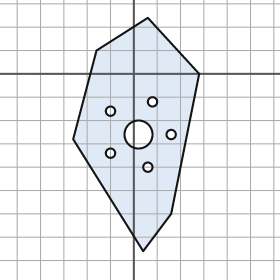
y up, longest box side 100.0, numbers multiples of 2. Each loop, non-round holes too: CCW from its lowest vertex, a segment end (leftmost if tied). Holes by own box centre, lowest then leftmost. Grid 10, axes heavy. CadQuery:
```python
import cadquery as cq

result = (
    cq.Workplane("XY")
    .moveTo(4.0, -76.0)
    .lineTo(16.0, -60.0)
    .lineTo(28.0, 0.0)
    .lineTo(6.0, 24.0)
    .lineTo(-16.0, 10.0)
    .lineTo(-26.0, -28.0)
    .close()
    .moveTo(6.0, -40.0)
    .circle(2.0)
    .moveTo(-10.0, -34.0)
    .circle(2.0)
    .moveTo(2.0, -26.0)
    .circle(6.0)
    .moveTo(16.0, -26.0)
    .circle(2.0)
    .moveTo(-10.0, -16.0)
    .circle(2.0)
    .moveTo(8.0, -12.0)
    .circle(2.0)
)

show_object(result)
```